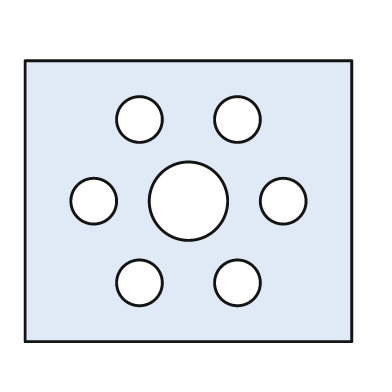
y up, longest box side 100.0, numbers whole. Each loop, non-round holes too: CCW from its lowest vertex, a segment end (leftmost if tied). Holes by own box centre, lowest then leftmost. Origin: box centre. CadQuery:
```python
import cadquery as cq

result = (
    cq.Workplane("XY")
    .moveTo(-50.0, -43.0)
    .lineTo(50.0, -43.0)
    .lineTo(50.0, 43.0)
    .lineTo(-50.0, 43.0)
    .close()
    .moveTo(-15.0, -25.0)
    .circle(7.0)
    .moveTo(15.0, -25.0)
    .circle(7.0)
    .moveTo(-29.0, 0.0)
    .circle(7.0)
    .moveTo(0.0, 0.0)
    .circle(12.0)
    .moveTo(29.0, 0.0)
    .circle(7.0)
    .moveTo(-15.0, 25.0)
    .circle(7.0)
    .moveTo(15.0, 25.0)
    .circle(7.0)
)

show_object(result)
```